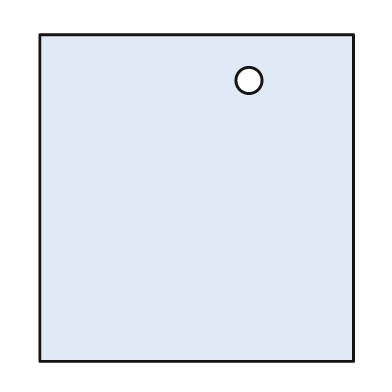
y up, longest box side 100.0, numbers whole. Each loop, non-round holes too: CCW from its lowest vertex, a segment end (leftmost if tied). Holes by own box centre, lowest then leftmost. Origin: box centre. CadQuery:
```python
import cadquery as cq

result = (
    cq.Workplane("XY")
    .moveTo(-48.0, -50.0)
    .lineTo(48.0, -50.0)
    .lineTo(48.0, 50.0)
    .lineTo(-48.0, 50.0)
    .close()
    .moveTo(16.0, 36.0)
    .circle(4.0)
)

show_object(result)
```